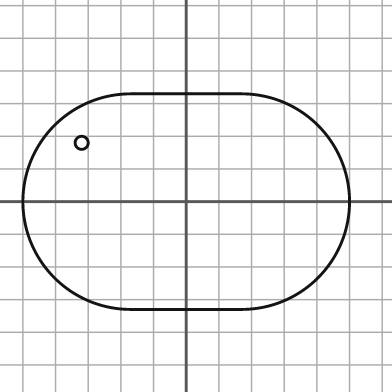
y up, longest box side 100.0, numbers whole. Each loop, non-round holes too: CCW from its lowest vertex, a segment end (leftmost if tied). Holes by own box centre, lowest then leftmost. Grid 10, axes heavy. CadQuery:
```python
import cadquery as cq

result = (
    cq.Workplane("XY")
    .moveTo(-17.0, -33.0)
    .lineTo(17.0, -33.0)
    .threePointArc((50.0, 0.0), (17.0, 33.0))
    .lineTo(-17.0, 33.0)
    .threePointArc((-50.0, 0.0), (-17.0, -33.0))
    .close()
    .moveTo(-32.0, 18.0)
    .circle(2.0)
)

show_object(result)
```